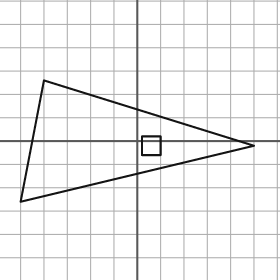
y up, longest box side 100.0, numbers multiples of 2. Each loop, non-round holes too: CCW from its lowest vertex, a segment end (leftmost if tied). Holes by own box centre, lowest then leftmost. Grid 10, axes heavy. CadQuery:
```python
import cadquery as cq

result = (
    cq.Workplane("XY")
    .moveTo(-50.0, -26.0)
    .lineTo(50.0, -2.0)
    .lineTo(-40.0, 26.0)
    .close()
    .moveTo(2.0, -6.0)
    .lineTo(10.0, -6.0)
    .lineTo(10.0, 2.0)
    .lineTo(2.0, 2.0)
    .close()
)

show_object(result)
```